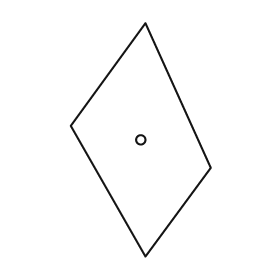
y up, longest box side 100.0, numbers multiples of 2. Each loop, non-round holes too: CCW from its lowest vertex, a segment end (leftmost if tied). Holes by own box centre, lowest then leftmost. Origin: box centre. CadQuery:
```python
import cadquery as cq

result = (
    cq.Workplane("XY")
    .moveTo(2.0, -50.0)
    .lineTo(30.0, -12.0)
    .lineTo(2.0, 50.0)
    .lineTo(-30.0, 6.0)
    .close()
    .moveTo(0.0, 0.0)
    .circle(2.0)
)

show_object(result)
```